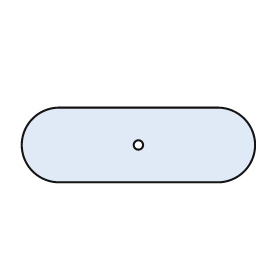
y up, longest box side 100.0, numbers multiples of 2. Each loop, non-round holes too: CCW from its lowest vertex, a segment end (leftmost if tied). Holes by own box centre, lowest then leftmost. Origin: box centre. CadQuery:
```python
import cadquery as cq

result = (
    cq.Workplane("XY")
    .moveTo(-34.0, -16.0)
    .lineTo(34.0, -16.0)
    .threePointArc((50.0, 0.0), (34.0, 16.0))
    .lineTo(-34.0, 16.0)
    .threePointArc((-50.0, 0.0), (-34.0, -16.0))
    .close()
    .moveTo(0.0, 0.0)
    .circle(2.0)
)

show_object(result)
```